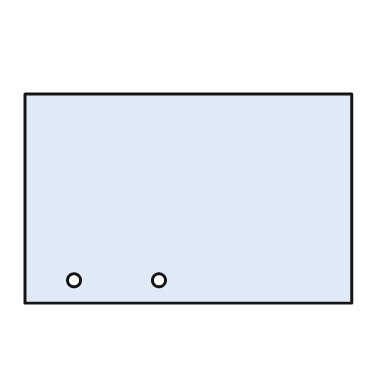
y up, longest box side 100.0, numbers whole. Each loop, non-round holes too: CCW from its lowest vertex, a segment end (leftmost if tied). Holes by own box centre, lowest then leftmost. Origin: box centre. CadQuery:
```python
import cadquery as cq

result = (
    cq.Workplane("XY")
    .moveTo(-50.0, -32.0)
    .lineTo(50.0, -32.0)
    .lineTo(50.0, 32.0)
    .lineTo(-50.0, 32.0)
    .close()
    .moveTo(-35.0, -25.0)
    .circle(2.0)
    .moveTo(-9.0, -25.0)
    .circle(2.0)
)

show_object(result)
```